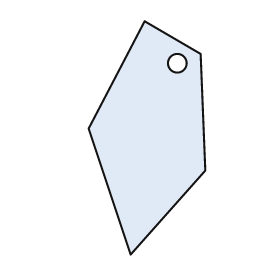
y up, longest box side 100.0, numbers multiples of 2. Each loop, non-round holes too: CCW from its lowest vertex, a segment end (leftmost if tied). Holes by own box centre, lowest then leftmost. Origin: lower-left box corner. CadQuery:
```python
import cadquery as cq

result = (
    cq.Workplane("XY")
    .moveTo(18.0, 0.0)
    .lineTo(50.0, 36.0)
    .lineTo(48.0, 86.0)
    .lineTo(24.0, 100.0)
    .lineTo(0.0, 54.0)
    .close()
    .moveTo(38.0, 82.0)
    .circle(4.0)
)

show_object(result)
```